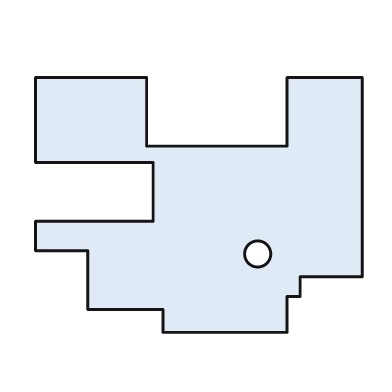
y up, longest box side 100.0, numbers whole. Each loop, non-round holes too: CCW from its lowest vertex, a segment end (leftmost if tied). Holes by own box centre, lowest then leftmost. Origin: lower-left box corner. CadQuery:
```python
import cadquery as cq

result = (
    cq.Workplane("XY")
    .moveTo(39.0, 0.0)
    .lineTo(77.0, 0.0)
    .lineTo(77.0, 11.0)
    .lineTo(81.0, 11.0)
    .lineTo(81.0, 17.0)
    .lineTo(100.0, 17.0)
    .lineTo(100.0, 78.0)
    .lineTo(77.0, 78.0)
    .lineTo(77.0, 57.0)
    .lineTo(34.0, 57.0)
    .lineTo(34.0, 78.0)
    .lineTo(0.0, 78.0)
    .lineTo(0.0, 52.0)
    .lineTo(36.0, 52.0)
    .lineTo(36.0, 34.0)
    .lineTo(0.0, 34.0)
    .lineTo(0.0, 25.0)
    .lineTo(16.0, 25.0)
    .lineTo(16.0, 7.0)
    .lineTo(39.0, 7.0)
    .close()
    .moveTo(68.0, 24.0)
    .circle(4.0)
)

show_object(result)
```